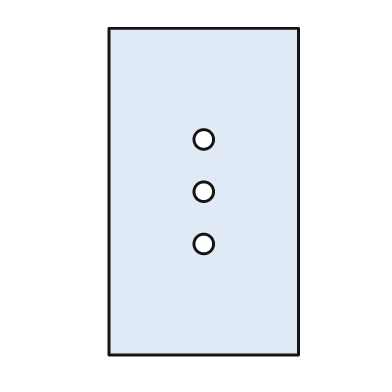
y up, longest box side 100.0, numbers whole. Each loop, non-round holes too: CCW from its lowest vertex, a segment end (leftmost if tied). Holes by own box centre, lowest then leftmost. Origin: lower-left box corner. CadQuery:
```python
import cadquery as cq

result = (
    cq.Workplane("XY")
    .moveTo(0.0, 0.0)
    .lineTo(58.0, 0.0)
    .lineTo(58.0, 100.0)
    .lineTo(0.0, 100.0)
    .close()
    .moveTo(29.0, 34.0)
    .circle(3.0)
    .moveTo(29.0, 50.0)
    .circle(3.0)
    .moveTo(29.0, 66.0)
    .circle(3.0)
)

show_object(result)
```